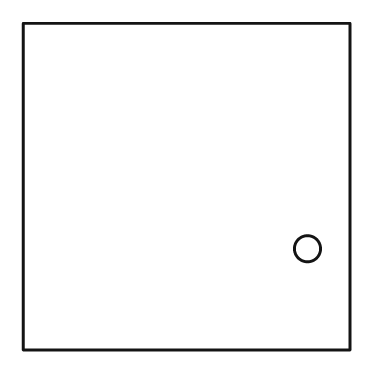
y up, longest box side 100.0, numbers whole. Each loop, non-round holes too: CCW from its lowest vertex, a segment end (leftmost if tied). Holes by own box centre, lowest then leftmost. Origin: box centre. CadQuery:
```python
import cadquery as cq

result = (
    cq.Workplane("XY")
    .moveTo(-50.0, -50.0)
    .lineTo(50.0, -50.0)
    .lineTo(50.0, 50.0)
    .lineTo(-50.0, 50.0)
    .close()
    .moveTo(37.0, -19.0)
    .circle(4.0)
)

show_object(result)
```